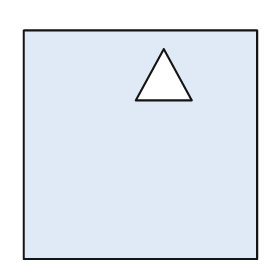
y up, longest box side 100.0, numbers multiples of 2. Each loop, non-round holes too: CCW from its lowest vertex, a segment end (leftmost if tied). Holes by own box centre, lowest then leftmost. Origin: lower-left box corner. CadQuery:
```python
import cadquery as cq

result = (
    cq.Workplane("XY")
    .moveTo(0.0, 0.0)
    .lineTo(100.0, 0.0)
    .lineTo(100.0, 98.0)
    .lineTo(0.0, 98.0)
    .close()
    .moveTo(48.0, 68.0)
    .lineTo(72.0, 68.0)
    .lineTo(60.0, 90.0)
    .close()
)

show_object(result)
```